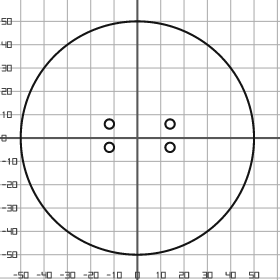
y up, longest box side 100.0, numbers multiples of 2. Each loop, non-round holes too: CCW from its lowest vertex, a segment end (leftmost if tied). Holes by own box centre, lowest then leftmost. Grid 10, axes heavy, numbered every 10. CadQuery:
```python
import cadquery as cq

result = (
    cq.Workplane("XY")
    .moveTo(0.0, 0.0)
    .circle(50.0)
    .moveTo(-12.0, -4.0)
    .circle(2.0)
    .moveTo(14.0, -4.0)
    .circle(2.0)
    .moveTo(-12.0, 6.0)
    .circle(2.0)
    .moveTo(14.0, 6.0)
    .circle(2.0)
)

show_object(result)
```